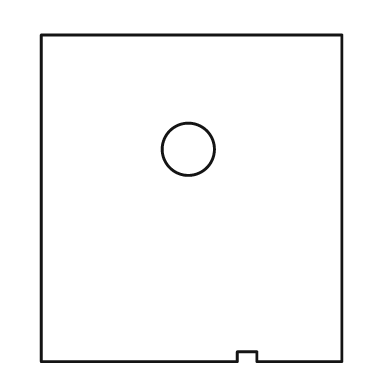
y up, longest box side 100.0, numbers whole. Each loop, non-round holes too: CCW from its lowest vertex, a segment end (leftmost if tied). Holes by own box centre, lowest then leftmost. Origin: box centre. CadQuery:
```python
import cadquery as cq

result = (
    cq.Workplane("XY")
    .moveTo(-46.0, -50.0)
    .lineTo(14.0, -50.0)
    .lineTo(14.0, -47.0)
    .lineTo(20.0, -47.0)
    .lineTo(20.0, -50.0)
    .lineTo(46.0, -50.0)
    .lineTo(46.0, 50.0)
    .lineTo(-46.0, 50.0)
    .close()
    .moveTo(-1.0, 15.0)
    .circle(8.0)
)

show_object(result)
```